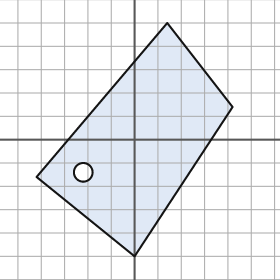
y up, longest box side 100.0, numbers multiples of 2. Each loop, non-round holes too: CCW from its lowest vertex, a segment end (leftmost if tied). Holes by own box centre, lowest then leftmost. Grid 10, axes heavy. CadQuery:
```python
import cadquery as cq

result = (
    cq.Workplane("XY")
    .moveTo(0.0, -50.0)
    .lineTo(42.0, 14.0)
    .lineTo(14.0, 50.0)
    .lineTo(-42.0, -16.0)
    .close()
    .moveTo(-22.0, -14.0)
    .circle(4.0)
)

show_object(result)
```